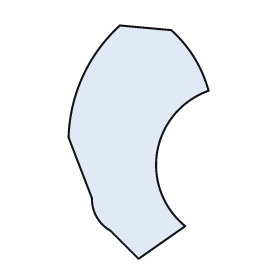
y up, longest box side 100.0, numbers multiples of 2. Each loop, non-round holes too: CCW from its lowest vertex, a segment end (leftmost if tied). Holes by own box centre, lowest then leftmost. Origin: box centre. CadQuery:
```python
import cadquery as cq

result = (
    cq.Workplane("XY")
    .moveTo(0.0, -50.0)
    .lineTo(20.0, -36.0)
    .threePointArc((8.0, -4.0), (30.0, 22.0))
    .threePointArc((24.0, 36.0), (14.0, 48.0))
    .lineTo(-8.0, 50.0)
    .threePointArc((-24.0, 28.0), (-30.0, 2.0))
    .lineTo(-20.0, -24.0)
    .threePointArc((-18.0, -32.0), (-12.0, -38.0))
    .close()
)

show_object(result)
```